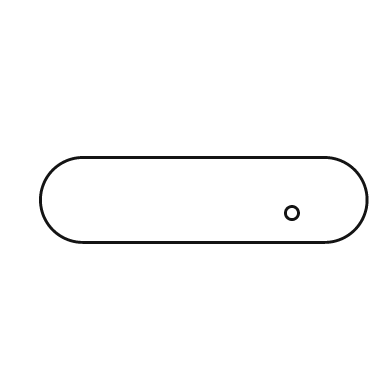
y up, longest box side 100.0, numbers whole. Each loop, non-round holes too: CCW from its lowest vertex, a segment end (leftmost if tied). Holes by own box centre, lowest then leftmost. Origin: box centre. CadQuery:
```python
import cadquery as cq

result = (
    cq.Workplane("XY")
    .moveTo(-37.0, -13.0)
    .lineTo(37.0, -13.0)
    .threePointArc((50.0, 0.0), (37.0, 13.0))
    .lineTo(-37.0, 13.0)
    .threePointArc((-50.0, 0.0), (-37.0, -13.0))
    .close()
    .moveTo(27.0, -4.0)
    .circle(2.0)
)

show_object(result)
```